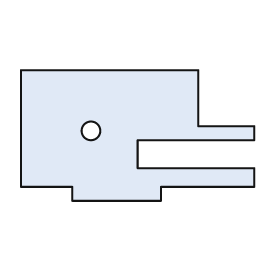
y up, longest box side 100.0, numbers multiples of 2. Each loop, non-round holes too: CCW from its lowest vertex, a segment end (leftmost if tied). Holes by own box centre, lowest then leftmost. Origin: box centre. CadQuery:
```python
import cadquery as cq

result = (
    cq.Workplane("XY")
    .moveTo(-28.0, -28.0)
    .lineTo(10.0, -28.0)
    .lineTo(10.0, -22.0)
    .lineTo(50.0, -22.0)
    .lineTo(50.0, -14.0)
    .lineTo(0.0, -14.0)
    .lineTo(0.0, -2.0)
    .lineTo(50.0, -2.0)
    .lineTo(50.0, 4.0)
    .lineTo(26.0, 4.0)
    .lineTo(26.0, 28.0)
    .lineTo(-50.0, 28.0)
    .lineTo(-50.0, -22.0)
    .lineTo(-28.0, -22.0)
    .close()
    .moveTo(-20.0, 2.0)
    .circle(4.0)
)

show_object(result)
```